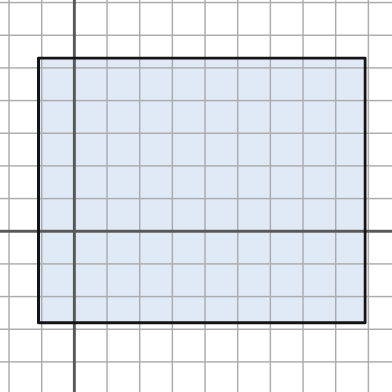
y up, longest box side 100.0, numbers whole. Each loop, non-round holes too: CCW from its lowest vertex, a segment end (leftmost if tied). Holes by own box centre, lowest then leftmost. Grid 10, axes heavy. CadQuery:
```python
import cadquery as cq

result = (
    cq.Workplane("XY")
    .moveTo(-11.0, -28.0)
    .lineTo(89.0, -28.0)
    .lineTo(89.0, 53.0)
    .lineTo(-11.0, 53.0)
    .close()
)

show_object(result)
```